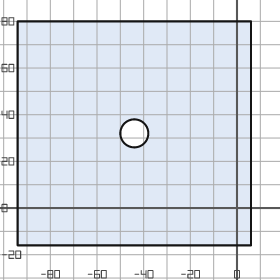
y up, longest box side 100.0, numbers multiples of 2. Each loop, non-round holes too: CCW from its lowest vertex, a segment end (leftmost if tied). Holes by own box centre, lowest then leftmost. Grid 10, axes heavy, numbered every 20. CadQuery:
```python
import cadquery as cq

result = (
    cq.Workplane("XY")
    .moveTo(-94.0, -16.0)
    .lineTo(6.0, -16.0)
    .lineTo(6.0, 80.0)
    .lineTo(-94.0, 80.0)
    .close()
    .moveTo(-44.0, 32.0)
    .circle(6.0)
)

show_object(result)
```